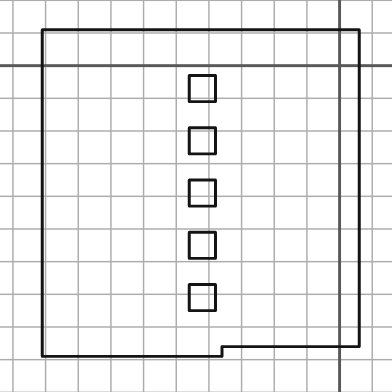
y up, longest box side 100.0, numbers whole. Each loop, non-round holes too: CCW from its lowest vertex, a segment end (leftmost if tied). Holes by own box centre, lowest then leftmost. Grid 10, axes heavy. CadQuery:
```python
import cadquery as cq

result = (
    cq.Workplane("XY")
    .moveTo(-91.0, -89.0)
    .lineTo(-36.0, -89.0)
    .lineTo(-36.0, -86.0)
    .lineTo(6.0, -86.0)
    .lineTo(6.0, 11.0)
    .lineTo(-91.0, 11.0)
    .close()
    .moveTo(-46.0, -75.0)
    .lineTo(-38.0, -75.0)
    .lineTo(-38.0, -67.0)
    .lineTo(-46.0, -67.0)
    .close()
    .moveTo(-46.0, -59.0)
    .lineTo(-38.0, -59.0)
    .lineTo(-38.0, -51.0)
    .lineTo(-46.0, -51.0)
    .close()
    .moveTo(-46.0, -43.0)
    .lineTo(-38.0, -43.0)
    .lineTo(-38.0, -35.0)
    .lineTo(-46.0, -35.0)
    .close()
    .moveTo(-46.0, -27.0)
    .lineTo(-38.0, -27.0)
    .lineTo(-38.0, -19.0)
    .lineTo(-46.0, -19.0)
    .close()
    .moveTo(-46.0, -11.0)
    .lineTo(-38.0, -11.0)
    .lineTo(-38.0, -3.0)
    .lineTo(-46.0, -3.0)
    .close()
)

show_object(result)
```